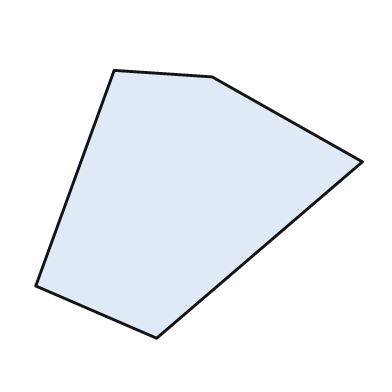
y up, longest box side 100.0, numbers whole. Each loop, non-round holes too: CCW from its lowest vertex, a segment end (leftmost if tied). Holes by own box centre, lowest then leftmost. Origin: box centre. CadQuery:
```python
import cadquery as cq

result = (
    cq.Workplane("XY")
    .moveTo(-13.0, -41.0)
    .lineTo(50.0, 13.0)
    .lineTo(4.0, 39.0)
    .lineTo(-26.0, 41.0)
    .lineTo(-50.0, -25.0)
    .close()
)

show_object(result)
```